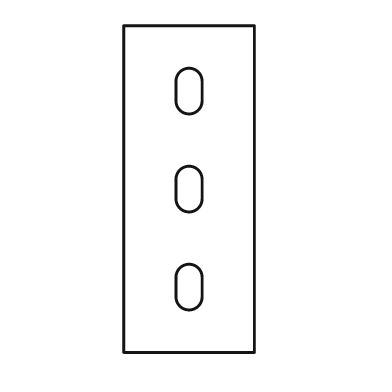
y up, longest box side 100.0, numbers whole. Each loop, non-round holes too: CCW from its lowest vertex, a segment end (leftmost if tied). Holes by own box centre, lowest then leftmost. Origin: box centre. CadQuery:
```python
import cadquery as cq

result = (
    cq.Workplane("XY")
    .moveTo(-20.0, -50.0)
    .lineTo(20.0, -50.0)
    .lineTo(20.0, 50.0)
    .lineTo(-20.0, 50.0)
    .close()
    .moveTo(-4.0, -33.0)
    .threePointArc((0.0, -37.0), (4.0, -33.0))
    .lineTo(4.0, -27.0)
    .threePointArc((0.0, -23.0), (-4.0, -27.0))
    .close()
    .moveTo(-4.0, -3.0)
    .threePointArc((0.0, -7.0), (4.0, -3.0))
    .lineTo(4.0, 3.0)
    .threePointArc((0.0, 7.0), (-4.0, 3.0))
    .close()
    .moveTo(-4.0, 27.0)
    .threePointArc((0.0, 23.0), (4.0, 27.0))
    .lineTo(4.0, 33.0)
    .threePointArc((0.0, 37.0), (-4.0, 33.0))
    .close()
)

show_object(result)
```